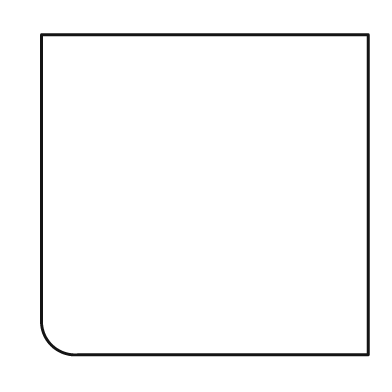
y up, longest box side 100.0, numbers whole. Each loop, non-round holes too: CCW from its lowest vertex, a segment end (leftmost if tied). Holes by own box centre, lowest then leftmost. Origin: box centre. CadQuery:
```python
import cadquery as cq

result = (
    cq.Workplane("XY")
    .moveTo(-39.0, -49.0)
    .lineTo(50.0, -49.0)
    .lineTo(50.0, 49.0)
    .lineTo(-50.0, 49.0)
    .lineTo(-50.0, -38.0)
    .threePointArc((-47.0, -46.0), (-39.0, -49.0))
    .close()
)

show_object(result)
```